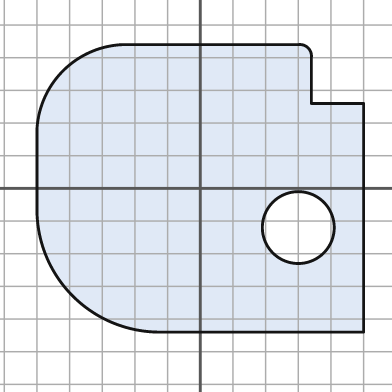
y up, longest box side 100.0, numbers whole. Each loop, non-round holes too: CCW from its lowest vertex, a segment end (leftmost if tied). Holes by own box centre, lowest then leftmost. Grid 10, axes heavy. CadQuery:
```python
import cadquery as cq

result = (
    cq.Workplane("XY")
    .moveTo(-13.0, -44.0)
    .lineTo(50.0, -44.0)
    .lineTo(50.0, 26.0)
    .lineTo(34.0, 26.0)
    .lineTo(34.0, 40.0)
    .threePointArc((33.0, 43.0), (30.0, 44.0))
    .lineTo(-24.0, 44.0)
    .threePointArc((-42.0, 36.0), (-50.0, 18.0))
    .lineTo(-50.0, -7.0)
    .threePointArc((-39.0, -33.0), (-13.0, -44.0))
    .close()
    .moveTo(30.0, -12.0)
    .circle(11.0)
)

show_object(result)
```